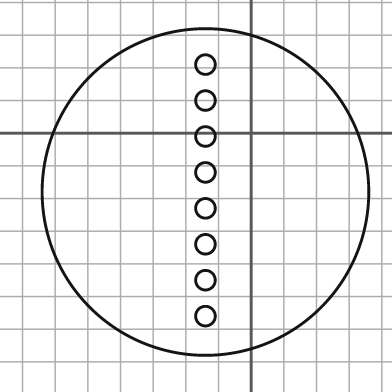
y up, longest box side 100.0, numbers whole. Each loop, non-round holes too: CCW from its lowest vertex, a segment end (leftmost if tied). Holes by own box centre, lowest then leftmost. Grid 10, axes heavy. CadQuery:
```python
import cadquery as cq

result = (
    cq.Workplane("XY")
    .moveTo(-14.0, -18.0)
    .circle(50.0)
    .moveTo(-14.0, -56.0)
    .circle(3.0)
    .moveTo(-14.0, -45.0)
    .circle(3.0)
    .moveTo(-14.0, -34.0)
    .circle(3.0)
    .moveTo(-14.0, -23.0)
    .circle(3.0)
    .moveTo(-14.0, -12.0)
    .circle(3.0)
    .moveTo(-14.0, -1.0)
    .circle(3.0)
    .moveTo(-14.0, 10.0)
    .circle(3.0)
    .moveTo(-14.0, 21.0)
    .circle(3.0)
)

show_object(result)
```